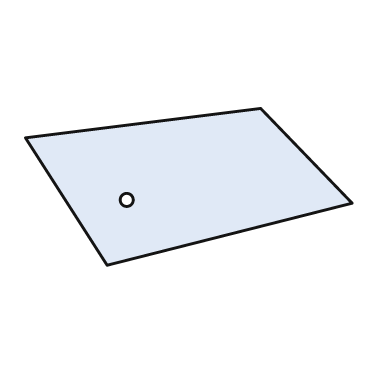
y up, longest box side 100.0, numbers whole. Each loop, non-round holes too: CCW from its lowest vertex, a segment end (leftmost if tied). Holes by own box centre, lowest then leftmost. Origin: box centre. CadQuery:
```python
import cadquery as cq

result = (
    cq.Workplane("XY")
    .moveTo(-25.0, -24.0)
    .lineTo(50.0, -5.0)
    .lineTo(22.0, 24.0)
    .lineTo(-50.0, 15.0)
    .close()
    .moveTo(-19.0, -4.0)
    .circle(2.0)
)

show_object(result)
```